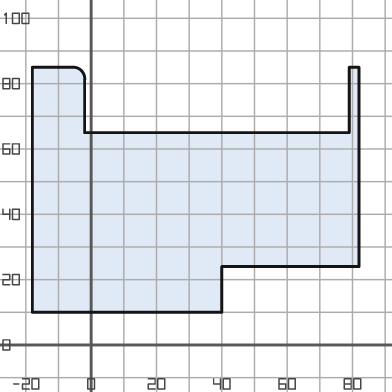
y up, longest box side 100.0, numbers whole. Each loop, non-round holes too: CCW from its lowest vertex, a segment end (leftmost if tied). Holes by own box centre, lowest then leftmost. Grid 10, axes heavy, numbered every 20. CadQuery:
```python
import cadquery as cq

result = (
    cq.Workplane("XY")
    .moveTo(-18.0, 10.0)
    .lineTo(40.0, 10.0)
    .lineTo(40.0, 24.0)
    .lineTo(82.0, 24.0)
    .lineTo(82.0, 85.0)
    .lineTo(79.0, 85.0)
    .lineTo(79.0, 65.0)
    .lineTo(-2.0, 65.0)
    .lineTo(-2.0, 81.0)
    .threePointArc((-3.0, 84.0), (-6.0, 85.0))
    .lineTo(-18.0, 85.0)
    .close()
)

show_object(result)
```